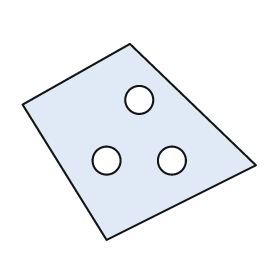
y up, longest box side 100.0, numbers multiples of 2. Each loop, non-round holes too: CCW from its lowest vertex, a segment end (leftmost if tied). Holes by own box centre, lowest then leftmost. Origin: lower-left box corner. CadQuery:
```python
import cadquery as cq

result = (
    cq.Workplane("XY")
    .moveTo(36.0, 0.0)
    .lineTo(100.0, 32.0)
    .lineTo(46.0, 84.0)
    .lineTo(0.0, 58.0)
    .close()
    .moveTo(36.0, 34.0)
    .circle(6.0)
    .moveTo(64.0, 34.0)
    .circle(6.0)
    .moveTo(50.0, 60.0)
    .circle(6.0)
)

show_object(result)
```